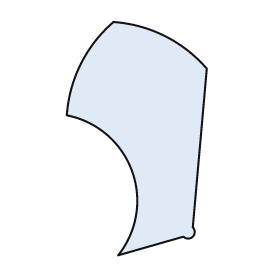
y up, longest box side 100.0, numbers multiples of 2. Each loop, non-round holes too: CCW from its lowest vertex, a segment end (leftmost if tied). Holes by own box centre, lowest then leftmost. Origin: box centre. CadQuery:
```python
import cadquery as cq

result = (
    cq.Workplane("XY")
    .moveTo(-8.0, -50.0)
    .lineTo(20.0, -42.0)
    .threePointArc((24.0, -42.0), (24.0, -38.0))
    .lineTo(30.0, 30.0)
    .threePointArc((12.0, 44.0), (-10.0, 50.0))
    .threePointArc((-24.0, 32.0), (-30.0, 10.0))
    .threePointArc((-2.0, -14.0), (-8.0, -50.0))
    .close()
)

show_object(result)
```